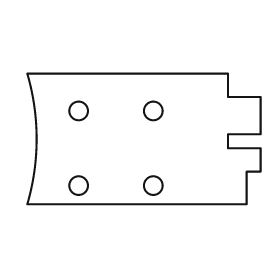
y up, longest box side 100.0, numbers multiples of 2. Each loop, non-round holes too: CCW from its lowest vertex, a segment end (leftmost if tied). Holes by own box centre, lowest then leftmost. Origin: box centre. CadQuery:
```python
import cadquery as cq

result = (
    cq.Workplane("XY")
    .moveTo(-50.0, -28.0)
    .lineTo(44.0, -28.0)
    .lineTo(44.0, -14.0)
    .lineTo(50.0, -14.0)
    .lineTo(50.0, -4.0)
    .lineTo(36.0, -4.0)
    .lineTo(36.0, 2.0)
    .lineTo(50.0, 2.0)
    .lineTo(50.0, 18.0)
    .lineTo(36.0, 18.0)
    .lineTo(36.0, 28.0)
    .lineTo(-50.0, 28.0)
    .threePointArc((-46.0, 0.0), (-50.0, -28.0))
    .close()
    .moveTo(-28.0, -20.0)
    .circle(4.0)
    .moveTo(4.0, -20.0)
    .circle(4.0)
    .moveTo(-28.0, 12.0)
    .circle(4.0)
    .moveTo(4.0, 12.0)
    .circle(4.0)
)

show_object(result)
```